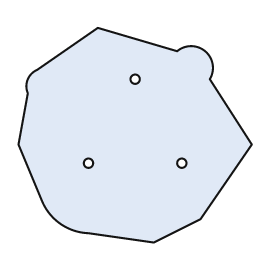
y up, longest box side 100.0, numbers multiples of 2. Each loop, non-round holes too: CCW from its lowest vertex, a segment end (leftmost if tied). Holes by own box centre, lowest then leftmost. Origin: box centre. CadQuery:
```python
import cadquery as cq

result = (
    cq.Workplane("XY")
    .moveTo(8.0, -46.0)
    .lineTo(28.0, -36.0)
    .lineTo(50.0, -4.0)
    .lineTo(32.0, 24.0)
    .threePointArc((30.0, 36.0), (18.0, 36.0))
    .lineTo(-16.0, 46.0)
    .lineTo(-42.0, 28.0)
    .threePointArc((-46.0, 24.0), (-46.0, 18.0))
    .lineTo(-50.0, -4.0)
    .lineTo(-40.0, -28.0)
    .threePointArc((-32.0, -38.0), (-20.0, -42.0))
    .close()
    .moveTo(-20.0, -12.0)
    .circle(2.0)
    .moveTo(20.0, -12.0)
    .circle(2.0)
    .moveTo(0.0, 24.0)
    .circle(2.0)
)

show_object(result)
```